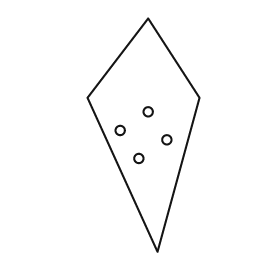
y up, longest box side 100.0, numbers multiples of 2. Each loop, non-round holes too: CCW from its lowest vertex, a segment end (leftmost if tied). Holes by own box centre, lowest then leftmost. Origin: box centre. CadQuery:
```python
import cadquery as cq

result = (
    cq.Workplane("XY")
    .moveTo(6.0, -50.0)
    .lineTo(24.0, 16.0)
    .lineTo(2.0, 50.0)
    .lineTo(-24.0, 16.0)
    .close()
    .moveTo(-2.0, -10.0)
    .circle(2.0)
    .moveTo(10.0, -2.0)
    .circle(2.0)
    .moveTo(-10.0, 2.0)
    .circle(2.0)
    .moveTo(2.0, 10.0)
    .circle(2.0)
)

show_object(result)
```